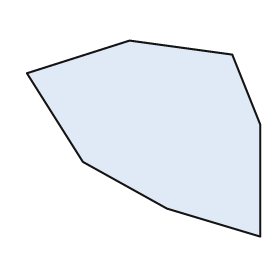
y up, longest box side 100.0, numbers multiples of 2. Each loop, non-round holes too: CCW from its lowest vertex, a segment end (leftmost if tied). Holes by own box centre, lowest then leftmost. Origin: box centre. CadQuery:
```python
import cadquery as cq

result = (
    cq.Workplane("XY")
    .moveTo(50.0, -42.0)
    .lineTo(50.0, 6.0)
    .lineTo(38.0, 36.0)
    .lineTo(-6.0, 42.0)
    .lineTo(-50.0, 28.0)
    .lineTo(-26.0, -10.0)
    .lineTo(10.0, -30.0)
    .close()
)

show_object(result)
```